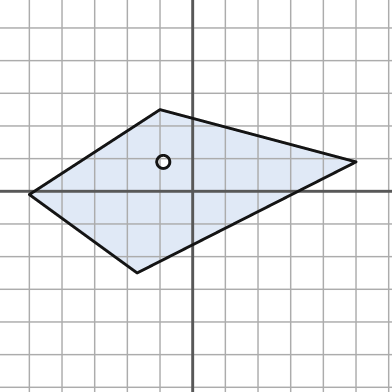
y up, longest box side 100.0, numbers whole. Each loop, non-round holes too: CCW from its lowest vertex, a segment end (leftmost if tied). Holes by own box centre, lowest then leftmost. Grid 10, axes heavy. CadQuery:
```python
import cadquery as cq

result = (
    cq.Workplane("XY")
    .moveTo(-17.0, -25.0)
    .lineTo(50.0, 9.0)
    .lineTo(-10.0, 25.0)
    .lineTo(-50.0, -1.0)
    .close()
    .moveTo(-9.0, 9.0)
    .circle(2.0)
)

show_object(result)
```